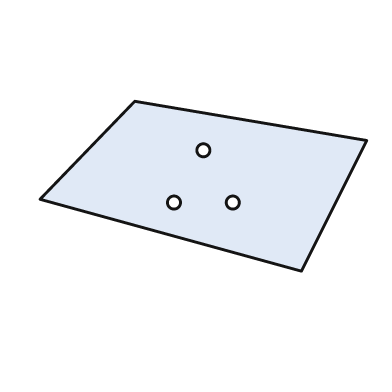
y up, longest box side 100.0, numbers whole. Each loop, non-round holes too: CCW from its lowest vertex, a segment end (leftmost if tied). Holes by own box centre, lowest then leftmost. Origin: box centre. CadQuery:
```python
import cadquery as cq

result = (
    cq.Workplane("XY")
    .moveTo(30.0, -26.0)
    .lineTo(50.0, 14.0)
    .lineTo(-21.0, 26.0)
    .lineTo(-50.0, -4.0)
    .close()
    .moveTo(-9.0, -5.0)
    .circle(2.0)
    .moveTo(9.0, -5.0)
    .circle(2.0)
    .moveTo(0.0, 11.0)
    .circle(2.0)
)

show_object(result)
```